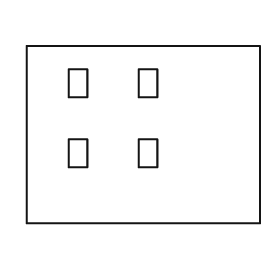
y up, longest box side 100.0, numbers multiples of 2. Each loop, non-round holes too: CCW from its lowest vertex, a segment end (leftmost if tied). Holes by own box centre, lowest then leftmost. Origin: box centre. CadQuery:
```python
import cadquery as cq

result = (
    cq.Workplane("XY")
    .moveTo(-50.0, -38.0)
    .lineTo(50.0, -38.0)
    .lineTo(50.0, 38.0)
    .lineTo(-50.0, 38.0)
    .close()
    .moveTo(-32.0, -14.0)
    .lineTo(-24.0, -14.0)
    .lineTo(-24.0, -2.0)
    .lineTo(-32.0, -2.0)
    .close()
    .moveTo(-2.0, -14.0)
    .lineTo(6.0, -14.0)
    .lineTo(6.0, -2.0)
    .lineTo(-2.0, -2.0)
    .close()
    .moveTo(-32.0, 16.0)
    .lineTo(-24.0, 16.0)
    .lineTo(-24.0, 28.0)
    .lineTo(-32.0, 28.0)
    .close()
    .moveTo(-2.0, 16.0)
    .lineTo(6.0, 16.0)
    .lineTo(6.0, 28.0)
    .lineTo(-2.0, 28.0)
    .close()
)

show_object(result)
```